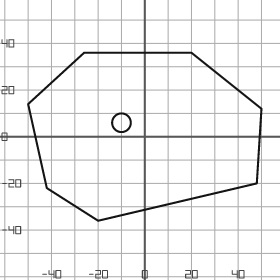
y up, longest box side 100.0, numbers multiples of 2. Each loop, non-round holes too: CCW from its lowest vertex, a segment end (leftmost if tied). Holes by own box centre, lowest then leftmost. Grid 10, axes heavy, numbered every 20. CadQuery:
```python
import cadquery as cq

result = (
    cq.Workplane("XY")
    .moveTo(-20.0, -36.0)
    .lineTo(48.0, -20.0)
    .lineTo(50.0, 12.0)
    .lineTo(20.0, 36.0)
    .lineTo(-26.0, 36.0)
    .lineTo(-50.0, 14.0)
    .lineTo(-42.0, -22.0)
    .close()
    .moveTo(-10.0, 6.0)
    .circle(4.0)
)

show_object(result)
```